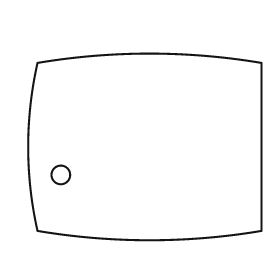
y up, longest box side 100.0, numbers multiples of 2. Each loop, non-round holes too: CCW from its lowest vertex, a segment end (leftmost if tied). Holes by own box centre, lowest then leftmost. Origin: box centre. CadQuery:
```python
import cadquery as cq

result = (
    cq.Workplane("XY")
    .moveTo(-46.0, -36.0)
    .threePointArc((2.0, -40.0), (50.0, -36.0))
    .lineTo(50.0, 36.0)
    .threePointArc((2.0, 40.0), (-46.0, 36.0))
    .threePointArc((-50.0, 0.0), (-46.0, -36.0))
    .close()
    .moveTo(-36.0, -12.0)
    .circle(4.0)
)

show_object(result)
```